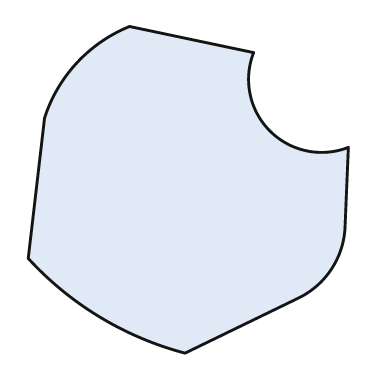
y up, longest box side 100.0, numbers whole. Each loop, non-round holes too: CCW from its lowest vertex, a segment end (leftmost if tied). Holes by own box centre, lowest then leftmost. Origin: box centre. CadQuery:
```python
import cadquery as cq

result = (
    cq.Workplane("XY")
    .moveTo(-1.0, -50.0)
    .lineTo(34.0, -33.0)
    .threePointArc((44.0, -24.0), (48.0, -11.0))
    .lineTo(49.0, 13.0)
    .threePointArc((25.0, 18.0), (20.0, 42.0))
    .lineTo(-18.0, 50.0)
    .threePointArc((-34.0, 39.0), (-44.0, 22.0))
    .lineTo(-49.0, -21.0)
    .threePointArc((-27.0, -39.0), (-1.0, -50.0))
    .close()
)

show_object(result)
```